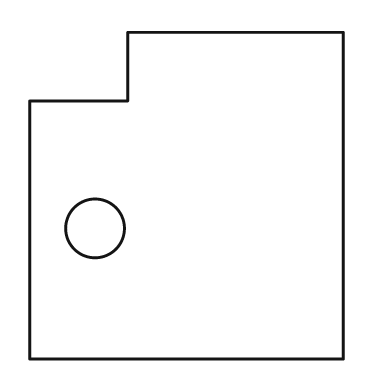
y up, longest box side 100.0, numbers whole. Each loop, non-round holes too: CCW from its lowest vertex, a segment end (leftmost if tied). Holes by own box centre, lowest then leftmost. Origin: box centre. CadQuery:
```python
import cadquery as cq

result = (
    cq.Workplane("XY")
    .moveTo(-48.0, -50.0)
    .lineTo(48.0, -50.0)
    .lineTo(48.0, 50.0)
    .lineTo(-18.0, 50.0)
    .lineTo(-18.0, 29.0)
    .lineTo(-48.0, 29.0)
    .close()
    .moveTo(-28.0, -10.0)
    .circle(9.0)
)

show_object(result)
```